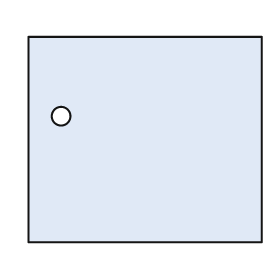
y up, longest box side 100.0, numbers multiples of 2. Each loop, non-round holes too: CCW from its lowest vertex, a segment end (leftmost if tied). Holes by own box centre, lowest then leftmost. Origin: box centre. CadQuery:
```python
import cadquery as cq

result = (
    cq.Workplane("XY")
    .moveTo(-50.0, -44.0)
    .lineTo(50.0, -44.0)
    .lineTo(50.0, 44.0)
    .lineTo(-50.0, 44.0)
    .close()
    .moveTo(-36.0, 10.0)
    .circle(4.0)
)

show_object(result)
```